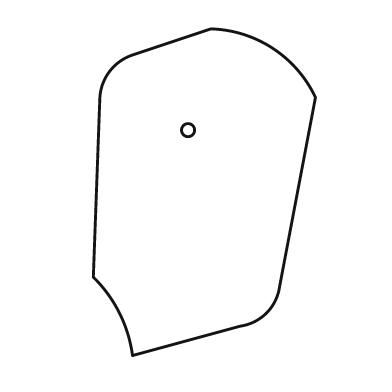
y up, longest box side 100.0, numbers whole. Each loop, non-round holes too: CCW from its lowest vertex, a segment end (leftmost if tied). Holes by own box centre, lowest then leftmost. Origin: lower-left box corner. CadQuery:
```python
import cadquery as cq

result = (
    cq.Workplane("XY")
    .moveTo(12.0, 0.0)
    .lineTo(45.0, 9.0)
    .threePointArc((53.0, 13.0), (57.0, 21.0))
    .lineTo(68.0, 79.0)
    .threePointArc((55.0, 94.0), (36.0, 100.0))
    .lineTo(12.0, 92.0)
    .threePointArc((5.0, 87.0), (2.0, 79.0))
    .lineTo(0.0, 24.0)
    .threePointArc((8.0, 13.0), (12.0, 0.0))
    .close()
    .moveTo(29.0, 69.0)
    .circle(2.0)
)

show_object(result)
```